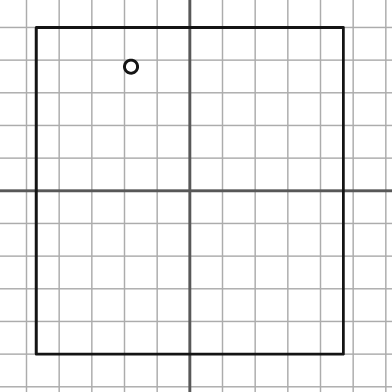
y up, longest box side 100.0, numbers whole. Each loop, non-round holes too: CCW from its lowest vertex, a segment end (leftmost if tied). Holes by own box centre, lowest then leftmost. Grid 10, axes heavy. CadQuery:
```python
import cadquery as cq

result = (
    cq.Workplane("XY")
    .moveTo(-47.0, -50.0)
    .lineTo(47.0, -50.0)
    .lineTo(47.0, 50.0)
    .lineTo(-47.0, 50.0)
    .close()
    .moveTo(-18.0, 38.0)
    .circle(2.0)
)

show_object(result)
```